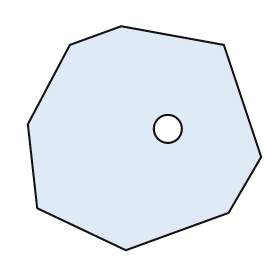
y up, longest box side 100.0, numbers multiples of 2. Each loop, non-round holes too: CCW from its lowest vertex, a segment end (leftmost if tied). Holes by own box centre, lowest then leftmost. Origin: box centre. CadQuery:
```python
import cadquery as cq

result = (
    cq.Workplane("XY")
    .moveTo(-8.0, -48.0)
    .lineTo(36.0, -32.0)
    .lineTo(50.0, -8.0)
    .lineTo(34.0, 40.0)
    .lineTo(-10.0, 48.0)
    .lineTo(-32.0, 40.0)
    .lineTo(-50.0, 6.0)
    .lineTo(-46.0, -30.0)
    .close()
    .moveTo(10.0, 4.0)
    .circle(6.0)
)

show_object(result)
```